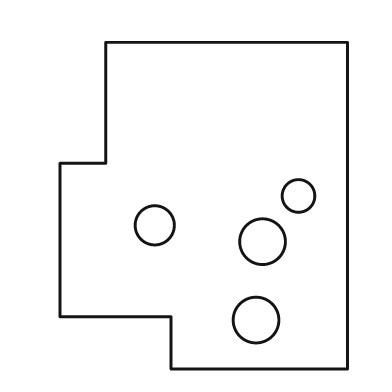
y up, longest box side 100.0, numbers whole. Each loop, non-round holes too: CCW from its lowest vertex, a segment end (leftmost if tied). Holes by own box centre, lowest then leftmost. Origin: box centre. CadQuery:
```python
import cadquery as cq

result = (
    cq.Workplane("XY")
    .moveTo(-10.0, -50.0)
    .lineTo(44.0, -50.0)
    .lineTo(44.0, 50.0)
    .lineTo(-30.0, 50.0)
    .lineTo(-30.0, 13.0)
    .lineTo(-44.0, 13.0)
    .lineTo(-44.0, -34.0)
    .lineTo(-10.0, -34.0)
    .close()
    .moveTo(16.0, -35.0)
    .circle(7.0)
    .moveTo(18.0, -11.0)
    .circle(7.0)
    .moveTo(-15.0, -6.0)
    .circle(6.0)
    .moveTo(29.0, 3.0)
    .circle(5.0)
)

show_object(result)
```